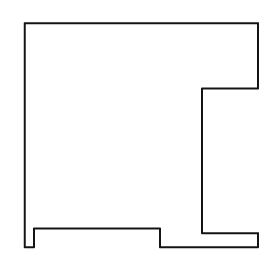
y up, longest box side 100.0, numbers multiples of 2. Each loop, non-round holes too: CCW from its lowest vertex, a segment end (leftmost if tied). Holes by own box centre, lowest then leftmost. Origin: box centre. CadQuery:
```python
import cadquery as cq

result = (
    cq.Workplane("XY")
    .moveTo(-50.0, -48.0)
    .lineTo(-46.0, -48.0)
    .lineTo(-46.0, -40.0)
    .lineTo(8.0, -40.0)
    .lineTo(8.0, -48.0)
    .lineTo(50.0, -48.0)
    .lineTo(50.0, -42.0)
    .lineTo(26.0, -42.0)
    .lineTo(26.0, 20.0)
    .lineTo(50.0, 20.0)
    .lineTo(50.0, 48.0)
    .lineTo(-50.0, 48.0)
    .close()
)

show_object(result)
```